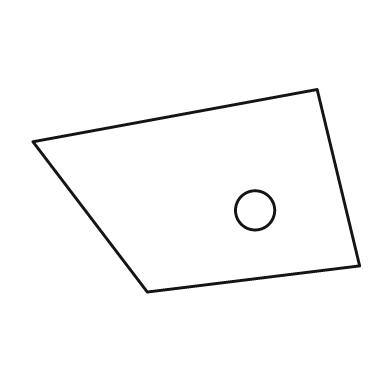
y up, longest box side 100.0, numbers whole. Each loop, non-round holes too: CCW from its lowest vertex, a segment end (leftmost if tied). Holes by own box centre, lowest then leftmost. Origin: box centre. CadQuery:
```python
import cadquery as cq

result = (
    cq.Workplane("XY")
    .moveTo(-15.0, -31.0)
    .lineTo(50.0, -23.0)
    .lineTo(37.0, 31.0)
    .lineTo(-50.0, 15.0)
    .close()
    .moveTo(18.0, -6.0)
    .circle(6.0)
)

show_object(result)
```